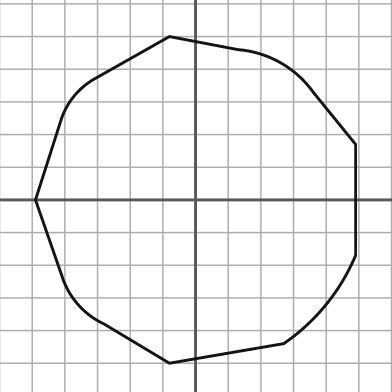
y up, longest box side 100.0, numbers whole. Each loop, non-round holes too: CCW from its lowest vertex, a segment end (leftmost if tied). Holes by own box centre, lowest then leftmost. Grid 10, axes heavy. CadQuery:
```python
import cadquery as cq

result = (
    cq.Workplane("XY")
    .moveTo(-8.0, -50.0)
    .lineTo(27.0, -44.0)
    .threePointArc((40.0, -32.0), (49.0, -17.0))
    .lineTo(49.0, 17.0)
    .lineTo(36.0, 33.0)
    .threePointArc((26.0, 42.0), (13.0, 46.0))
    .lineTo(-8.0, 50.0)
    .lineTo(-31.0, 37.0)
    .threePointArc((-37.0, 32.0), (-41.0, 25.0))
    .lineTo(-49.0, 0.0)
    .lineTo(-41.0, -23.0)
    .threePointArc((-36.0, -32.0), (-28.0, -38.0))
    .close()
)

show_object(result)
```